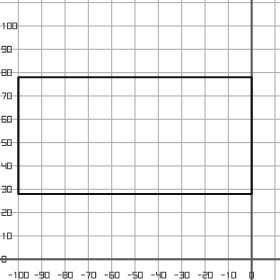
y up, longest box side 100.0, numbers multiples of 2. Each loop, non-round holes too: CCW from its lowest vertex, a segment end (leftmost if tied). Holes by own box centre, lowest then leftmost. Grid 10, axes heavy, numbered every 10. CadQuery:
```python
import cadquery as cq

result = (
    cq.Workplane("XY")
    .moveTo(-100.0, 28.0)
    .lineTo(0.0, 28.0)
    .lineTo(0.0, 78.0)
    .lineTo(-100.0, 78.0)
    .close()
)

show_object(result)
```